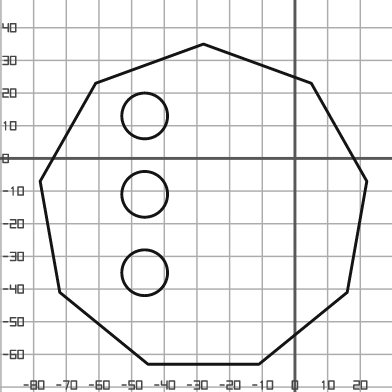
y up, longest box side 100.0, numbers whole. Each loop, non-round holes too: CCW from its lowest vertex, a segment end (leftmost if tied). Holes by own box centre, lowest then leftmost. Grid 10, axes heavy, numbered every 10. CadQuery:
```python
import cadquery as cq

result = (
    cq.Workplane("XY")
    .moveTo(-45.0, -63.0)
    .lineTo(-11.0, -63.0)
    .lineTo(16.0, -41.0)
    .lineTo(22.0, -7.0)
    .lineTo(5.0, 23.0)
    .lineTo(-28.0, 35.0)
    .lineTo(-61.0, 23.0)
    .lineTo(-78.0, -7.0)
    .lineTo(-72.0, -41.0)
    .close()
    .moveTo(-46.0, -35.0)
    .circle(7.0)
    .moveTo(-46.0, -11.0)
    .circle(7.0)
    .moveTo(-46.0, 13.0)
    .circle(7.0)
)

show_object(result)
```